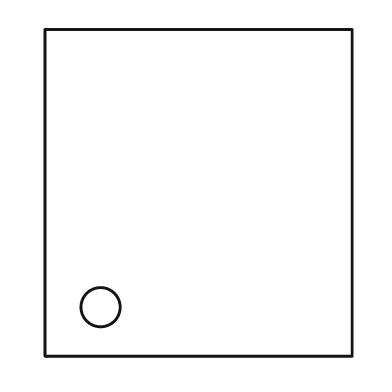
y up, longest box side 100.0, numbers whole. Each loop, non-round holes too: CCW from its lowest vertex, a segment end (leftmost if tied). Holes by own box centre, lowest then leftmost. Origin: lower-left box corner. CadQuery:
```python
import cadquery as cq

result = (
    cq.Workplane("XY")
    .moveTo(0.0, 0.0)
    .lineTo(94.0, 0.0)
    .lineTo(94.0, 100.0)
    .lineTo(0.0, 100.0)
    .close()
    .moveTo(17.0, 15.0)
    .circle(6.0)
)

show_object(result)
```